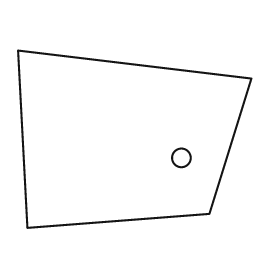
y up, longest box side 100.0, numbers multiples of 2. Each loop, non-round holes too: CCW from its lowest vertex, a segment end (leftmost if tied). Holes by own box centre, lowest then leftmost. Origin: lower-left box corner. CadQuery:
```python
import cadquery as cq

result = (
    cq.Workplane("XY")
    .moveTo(4.0, 0.0)
    .lineTo(82.0, 6.0)
    .lineTo(100.0, 64.0)
    .lineTo(0.0, 76.0)
    .close()
    .moveTo(70.0, 30.0)
    .circle(4.0)
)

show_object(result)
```